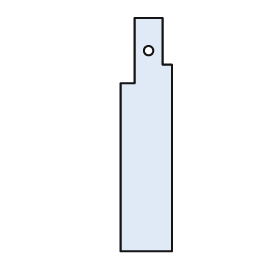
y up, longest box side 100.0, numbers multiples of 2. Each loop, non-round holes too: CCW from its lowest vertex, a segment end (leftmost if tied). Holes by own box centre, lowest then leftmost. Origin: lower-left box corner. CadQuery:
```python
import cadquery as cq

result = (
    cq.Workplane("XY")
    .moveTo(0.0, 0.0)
    .lineTo(22.0, 0.0)
    .lineTo(22.0, 80.0)
    .lineTo(18.0, 80.0)
    .lineTo(18.0, 100.0)
    .lineTo(6.0, 100.0)
    .lineTo(6.0, 72.0)
    .lineTo(0.0, 72.0)
    .close()
    .moveTo(12.0, 86.0)
    .circle(2.0)
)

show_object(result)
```